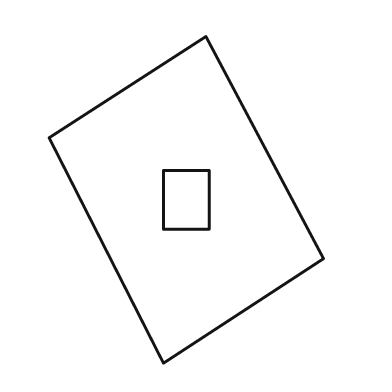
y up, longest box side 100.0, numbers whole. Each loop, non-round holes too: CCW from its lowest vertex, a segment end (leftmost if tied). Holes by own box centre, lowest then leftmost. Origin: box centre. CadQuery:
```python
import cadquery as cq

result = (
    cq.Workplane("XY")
    .moveTo(-7.0, -50.0)
    .lineTo(42.0, -18.0)
    .lineTo(6.0, 50.0)
    .lineTo(-42.0, 19.0)
    .close()
    .moveTo(-7.0, -9.0)
    .lineTo(7.0, -9.0)
    .lineTo(7.0, 9.0)
    .lineTo(-7.0, 9.0)
    .close()
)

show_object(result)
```